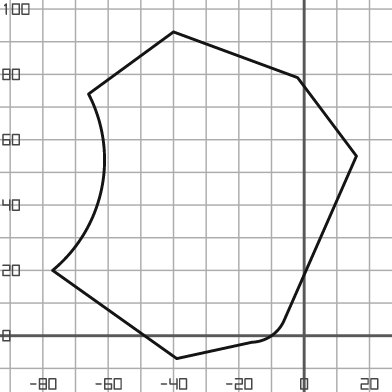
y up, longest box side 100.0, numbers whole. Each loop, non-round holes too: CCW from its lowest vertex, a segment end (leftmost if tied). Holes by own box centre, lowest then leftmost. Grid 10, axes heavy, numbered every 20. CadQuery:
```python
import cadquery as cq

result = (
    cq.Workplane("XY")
    .moveTo(-39.0, -7.0)
    .lineTo(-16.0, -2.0)
    .threePointArc((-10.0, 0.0), (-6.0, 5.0))
    .lineTo(16.0, 55.0)
    .lineTo(-2.0, 79.0)
    .lineTo(-40.0, 93.0)
    .lineTo(-66.0, 74.0)
    .threePointArc((-62.0, 45.0), (-77.0, 20.0))
    .close()
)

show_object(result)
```